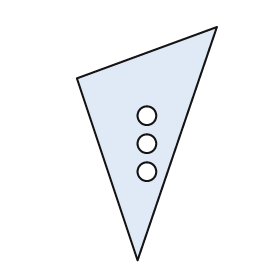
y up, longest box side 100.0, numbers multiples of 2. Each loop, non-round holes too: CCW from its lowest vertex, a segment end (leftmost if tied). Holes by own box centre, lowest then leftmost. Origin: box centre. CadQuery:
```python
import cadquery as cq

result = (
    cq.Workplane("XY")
    .moveTo(-4.0, -50.0)
    .lineTo(30.0, 50.0)
    .lineTo(-30.0, 28.0)
    .close()
    .moveTo(0.0, -12.0)
    .circle(4.0)
    .moveTo(0.0, 0.0)
    .circle(4.0)
    .moveTo(0.0, 12.0)
    .circle(4.0)
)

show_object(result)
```